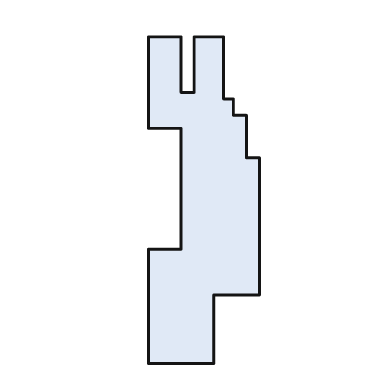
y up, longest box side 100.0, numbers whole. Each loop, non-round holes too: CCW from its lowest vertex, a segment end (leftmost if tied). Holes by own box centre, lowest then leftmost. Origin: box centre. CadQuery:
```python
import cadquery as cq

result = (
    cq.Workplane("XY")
    .moveTo(-17.0, -50.0)
    .lineTo(3.0, -50.0)
    .lineTo(3.0, -29.0)
    .lineTo(17.0, -29.0)
    .lineTo(17.0, 13.0)
    .lineTo(13.0, 13.0)
    .lineTo(13.0, 26.0)
    .lineTo(9.0, 26.0)
    .lineTo(9.0, 31.0)
    .lineTo(6.0, 31.0)
    .lineTo(6.0, 50.0)
    .lineTo(-3.0, 50.0)
    .lineTo(-3.0, 33.0)
    .lineTo(-7.0, 33.0)
    .lineTo(-7.0, 50.0)
    .lineTo(-17.0, 50.0)
    .lineTo(-17.0, 22.0)
    .lineTo(-7.0, 22.0)
    .lineTo(-7.0, -15.0)
    .lineTo(-17.0, -15.0)
    .close()
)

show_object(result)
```